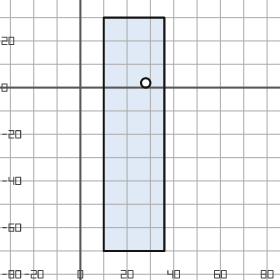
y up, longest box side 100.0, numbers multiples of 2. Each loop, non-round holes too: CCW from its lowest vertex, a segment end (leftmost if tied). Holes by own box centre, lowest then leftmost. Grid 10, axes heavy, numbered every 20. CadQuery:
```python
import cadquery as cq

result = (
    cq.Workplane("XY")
    .moveTo(10.0, -70.0)
    .lineTo(36.0, -70.0)
    .lineTo(36.0, 30.0)
    .lineTo(10.0, 30.0)
    .close()
    .moveTo(28.0, 2.0)
    .circle(2.0)
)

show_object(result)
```